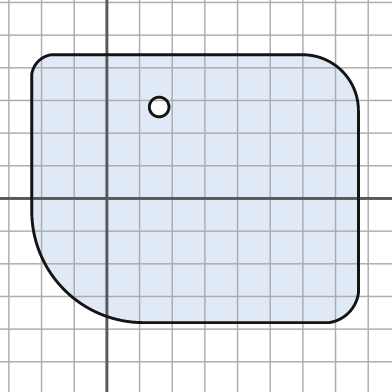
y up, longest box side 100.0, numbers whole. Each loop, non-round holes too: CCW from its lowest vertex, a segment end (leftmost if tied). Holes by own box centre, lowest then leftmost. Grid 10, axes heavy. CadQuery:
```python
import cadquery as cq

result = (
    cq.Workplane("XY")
    .moveTo(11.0, -38.0)
    .lineTo(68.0, -38.0)
    .threePointArc((74.0, -35.0), (77.0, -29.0))
    .lineTo(77.0, 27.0)
    .threePointArc((72.0, 39.0), (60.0, 44.0))
    .lineTo(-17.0, 44.0)
    .threePointArc((-21.0, 42.0), (-23.0, 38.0))
    .lineTo(-23.0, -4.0)
    .threePointArc((-13.0, -28.0), (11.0, -38.0))
    .close()
    .moveTo(16.0, 28.0)
    .circle(3.0)
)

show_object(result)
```